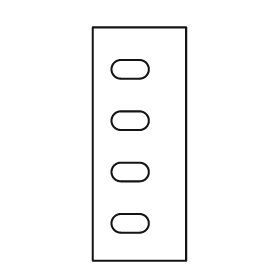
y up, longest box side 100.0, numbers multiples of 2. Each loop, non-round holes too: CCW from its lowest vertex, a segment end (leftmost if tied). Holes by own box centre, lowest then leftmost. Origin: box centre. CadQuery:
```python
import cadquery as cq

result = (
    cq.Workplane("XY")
    .moveTo(-20.0, -50.0)
    .lineTo(20.0, -50.0)
    .lineTo(20.0, 50.0)
    .lineTo(-20.0, 50.0)
    .close()
    .moveTo(-8.0, -38.0)
    .lineTo(0.0, -38.0)
    .threePointArc((4.0, -34.0), (0.0, -30.0))
    .lineTo(-8.0, -30.0)
    .threePointArc((-12.0, -34.0), (-8.0, -38.0))
    .close()
    .moveTo(-8.0, -16.0)
    .lineTo(0.0, -16.0)
    .threePointArc((4.0, -12.0), (0.0, -8.0))
    .lineTo(-8.0, -8.0)
    .threePointArc((-12.0, -12.0), (-8.0, -16.0))
    .close()
    .moveTo(-8.0, 6.0)
    .lineTo(0.0, 6.0)
    .threePointArc((4.0, 10.0), (0.0, 14.0))
    .lineTo(-8.0, 14.0)
    .threePointArc((-12.0, 10.0), (-8.0, 6.0))
    .close()
    .moveTo(-8.0, 28.0)
    .lineTo(0.0, 28.0)
    .threePointArc((4.0, 32.0), (0.0, 36.0))
    .lineTo(-8.0, 36.0)
    .threePointArc((-12.0, 32.0), (-8.0, 28.0))
    .close()
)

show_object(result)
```